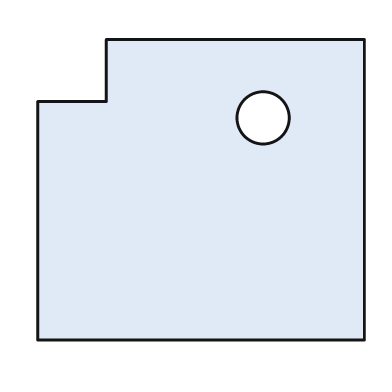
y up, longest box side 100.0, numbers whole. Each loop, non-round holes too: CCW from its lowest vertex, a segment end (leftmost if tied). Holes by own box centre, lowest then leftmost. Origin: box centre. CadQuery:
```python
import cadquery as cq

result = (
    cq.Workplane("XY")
    .moveTo(-50.0, -46.0)
    .lineTo(50.0, -46.0)
    .lineTo(50.0, 46.0)
    .lineTo(-29.0, 46.0)
    .lineTo(-29.0, 27.0)
    .lineTo(-50.0, 27.0)
    .close()
    .moveTo(19.0, 22.0)
    .circle(8.0)
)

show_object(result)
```